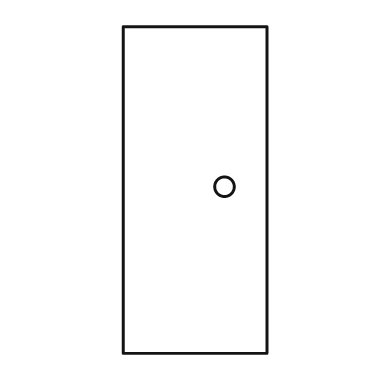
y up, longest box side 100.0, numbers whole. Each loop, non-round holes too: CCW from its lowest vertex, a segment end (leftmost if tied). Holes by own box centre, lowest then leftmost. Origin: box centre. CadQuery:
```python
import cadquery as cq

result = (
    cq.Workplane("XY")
    .moveTo(-22.0, -50.0)
    .lineTo(22.0, -50.0)
    .lineTo(22.0, 50.0)
    .lineTo(-22.0, 50.0)
    .close()
    .moveTo(9.0, 1.0)
    .circle(3.0)
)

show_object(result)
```